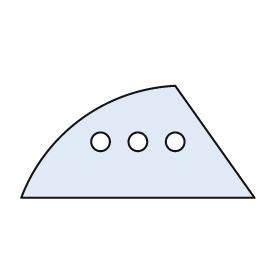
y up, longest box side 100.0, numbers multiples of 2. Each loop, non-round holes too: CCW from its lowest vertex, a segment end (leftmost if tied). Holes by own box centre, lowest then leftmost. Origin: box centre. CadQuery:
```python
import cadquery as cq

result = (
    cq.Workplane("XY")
    .moveTo(-50.0, -24.0)
    .lineTo(50.0, -24.0)
    .lineTo(16.0, 24.0)
    .threePointArc((-24.0, 10.0), (-50.0, -24.0))
    .close()
    .moveTo(-16.0, 0.0)
    .circle(4.0)
    .moveTo(0.0, 0.0)
    .circle(4.0)
    .moveTo(16.0, 0.0)
    .circle(4.0)
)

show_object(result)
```